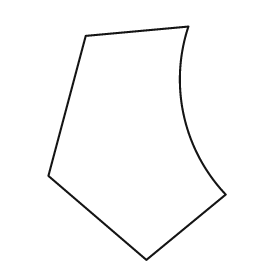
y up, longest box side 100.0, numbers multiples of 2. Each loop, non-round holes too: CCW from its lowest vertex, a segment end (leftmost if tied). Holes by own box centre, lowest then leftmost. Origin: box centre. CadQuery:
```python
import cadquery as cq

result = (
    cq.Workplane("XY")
    .moveTo(4.0, -50.0)
    .lineTo(38.0, -22.0)
    .threePointArc((20.0, 12.0), (22.0, 50.0))
    .lineTo(-22.0, 46.0)
    .lineTo(-38.0, -14.0)
    .close()
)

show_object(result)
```